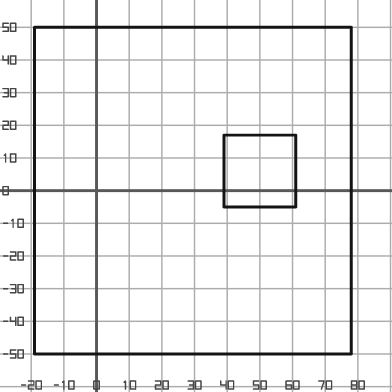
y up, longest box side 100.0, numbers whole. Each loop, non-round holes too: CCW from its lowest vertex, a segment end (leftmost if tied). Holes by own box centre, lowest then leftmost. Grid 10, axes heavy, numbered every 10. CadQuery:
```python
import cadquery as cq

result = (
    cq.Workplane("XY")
    .moveTo(-19.0, -50.0)
    .lineTo(78.0, -50.0)
    .lineTo(78.0, 50.0)
    .lineTo(-19.0, 50.0)
    .close()
    .moveTo(39.0, -5.0)
    .lineTo(61.0, -5.0)
    .lineTo(61.0, 17.0)
    .lineTo(39.0, 17.0)
    .close()
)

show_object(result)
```